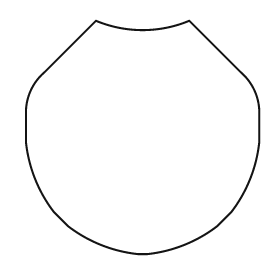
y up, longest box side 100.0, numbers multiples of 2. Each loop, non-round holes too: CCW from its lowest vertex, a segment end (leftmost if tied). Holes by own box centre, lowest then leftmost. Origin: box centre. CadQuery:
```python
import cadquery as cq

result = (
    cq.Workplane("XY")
    .moveTo(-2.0, -50.0)
    .lineTo(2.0, -50.0)
    .threePointArc((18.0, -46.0), (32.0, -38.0))
    .lineTo(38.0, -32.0)
    .threePointArc((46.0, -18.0), (50.0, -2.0))
    .lineTo(50.0, 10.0)
    .threePointArc((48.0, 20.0), (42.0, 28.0))
    .lineTo(20.0, 50.0)
    .threePointArc((0.0, 46.0), (-20.0, 50.0))
    .lineTo(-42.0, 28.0)
    .threePointArc((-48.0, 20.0), (-50.0, 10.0))
    .lineTo(-50.0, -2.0)
    .threePointArc((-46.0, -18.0), (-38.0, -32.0))
    .lineTo(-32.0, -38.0)
    .threePointArc((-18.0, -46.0), (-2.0, -50.0))
    .close()
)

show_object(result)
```